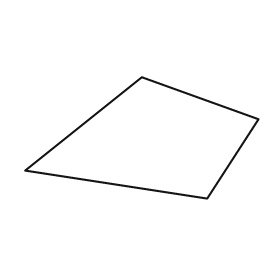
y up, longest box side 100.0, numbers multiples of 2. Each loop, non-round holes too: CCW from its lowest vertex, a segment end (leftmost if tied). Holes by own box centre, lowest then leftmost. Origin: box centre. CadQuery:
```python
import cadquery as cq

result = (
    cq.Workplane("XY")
    .moveTo(28.0, -26.0)
    .lineTo(50.0, 8.0)
    .lineTo(0.0, 26.0)
    .lineTo(-50.0, -14.0)
    .close()
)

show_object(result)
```